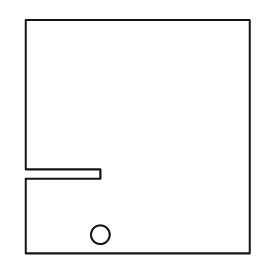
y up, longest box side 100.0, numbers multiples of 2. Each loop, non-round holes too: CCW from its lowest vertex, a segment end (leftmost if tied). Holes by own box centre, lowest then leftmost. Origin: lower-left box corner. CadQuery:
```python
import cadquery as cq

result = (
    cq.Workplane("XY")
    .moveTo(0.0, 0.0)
    .lineTo(96.0, 0.0)
    .lineTo(96.0, 100.0)
    .lineTo(0.0, 100.0)
    .lineTo(0.0, 36.0)
    .lineTo(32.0, 36.0)
    .lineTo(32.0, 32.0)
    .lineTo(0.0, 32.0)
    .close()
    .moveTo(32.0, 8.0)
    .circle(4.0)
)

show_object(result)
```